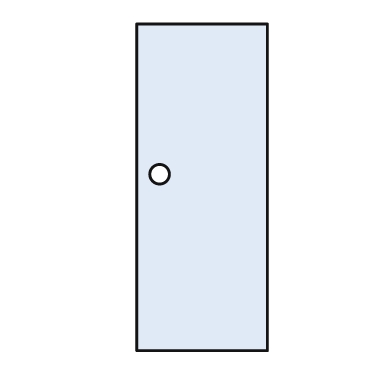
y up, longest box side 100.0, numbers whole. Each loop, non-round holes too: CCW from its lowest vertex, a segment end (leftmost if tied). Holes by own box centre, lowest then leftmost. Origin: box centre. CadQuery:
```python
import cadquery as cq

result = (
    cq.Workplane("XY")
    .moveTo(-20.0, -50.0)
    .lineTo(20.0, -50.0)
    .lineTo(20.0, 50.0)
    .lineTo(-20.0, 50.0)
    .close()
    .moveTo(-13.0, 4.0)
    .circle(3.0)
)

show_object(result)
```